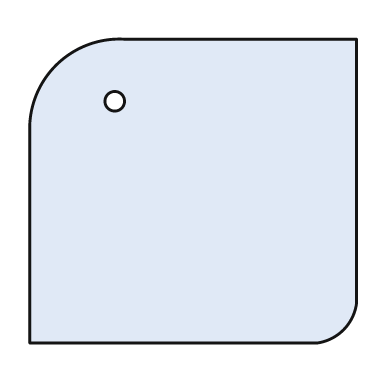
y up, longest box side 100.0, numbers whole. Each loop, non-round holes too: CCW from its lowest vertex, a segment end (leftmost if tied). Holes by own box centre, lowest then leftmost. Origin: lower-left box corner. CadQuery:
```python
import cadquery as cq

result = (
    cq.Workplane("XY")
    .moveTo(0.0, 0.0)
    .lineTo(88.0, 0.0)
    .threePointArc((96.0, 4.0), (100.0, 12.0))
    .lineTo(100.0, 93.0)
    .lineTo(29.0, 93.0)
    .threePointArc((8.0, 85.0), (0.0, 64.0))
    .close()
    .moveTo(26.0, 74.0)
    .circle(3.0)
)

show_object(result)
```